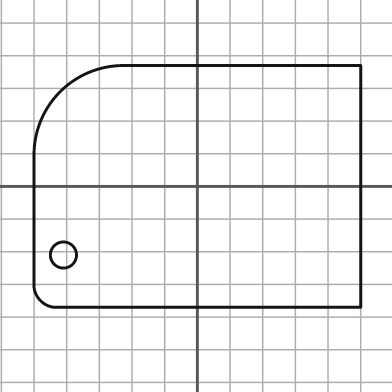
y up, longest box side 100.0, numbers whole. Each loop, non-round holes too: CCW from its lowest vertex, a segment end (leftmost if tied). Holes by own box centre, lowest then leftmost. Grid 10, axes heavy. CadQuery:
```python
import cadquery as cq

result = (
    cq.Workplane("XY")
    .moveTo(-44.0, -37.0)
    .lineTo(50.0, -37.0)
    .lineTo(50.0, 37.0)
    .lineTo(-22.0, 37.0)
    .threePointArc((-42.0, 29.0), (-50.0, 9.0))
    .lineTo(-50.0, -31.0)
    .threePointArc((-48.0, -35.0), (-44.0, -37.0))
    .close()
    .moveTo(-41.0, -21.0)
    .circle(4.0)
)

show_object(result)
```